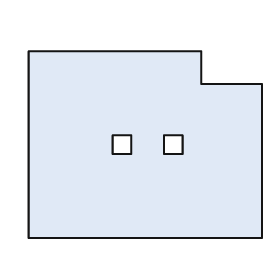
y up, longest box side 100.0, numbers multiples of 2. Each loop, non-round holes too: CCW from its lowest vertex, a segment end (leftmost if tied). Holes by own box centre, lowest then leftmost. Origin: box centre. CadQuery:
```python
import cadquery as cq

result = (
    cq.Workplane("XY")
    .moveTo(-50.0, -40.0)
    .lineTo(50.0, -40.0)
    .lineTo(50.0, 26.0)
    .lineTo(24.0, 26.0)
    .lineTo(24.0, 40.0)
    .lineTo(-50.0, 40.0)
    .close()
    .moveTo(-14.0, -4.0)
    .lineTo(-6.0, -4.0)
    .lineTo(-6.0, 4.0)
    .lineTo(-14.0, 4.0)
    .close()
    .moveTo(8.0, -4.0)
    .lineTo(16.0, -4.0)
    .lineTo(16.0, 4.0)
    .lineTo(8.0, 4.0)
    .close()
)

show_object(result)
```